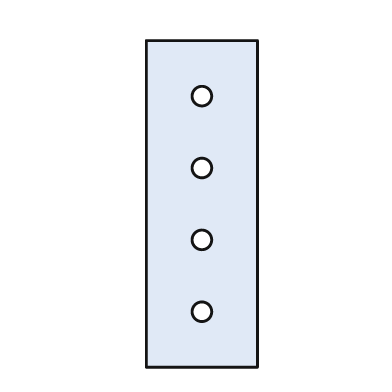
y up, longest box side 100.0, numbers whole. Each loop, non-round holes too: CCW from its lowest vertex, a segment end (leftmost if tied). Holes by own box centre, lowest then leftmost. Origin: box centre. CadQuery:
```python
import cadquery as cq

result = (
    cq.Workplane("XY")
    .moveTo(-17.0, -50.0)
    .lineTo(17.0, -50.0)
    .lineTo(17.0, 50.0)
    .lineTo(-17.0, 50.0)
    .close()
    .moveTo(0.0, -33.0)
    .circle(3.0)
    .moveTo(0.0, -11.0)
    .circle(3.0)
    .moveTo(0.0, 11.0)
    .circle(3.0)
    .moveTo(0.0, 33.0)
    .circle(3.0)
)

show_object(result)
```